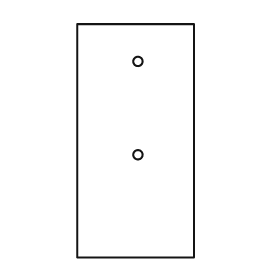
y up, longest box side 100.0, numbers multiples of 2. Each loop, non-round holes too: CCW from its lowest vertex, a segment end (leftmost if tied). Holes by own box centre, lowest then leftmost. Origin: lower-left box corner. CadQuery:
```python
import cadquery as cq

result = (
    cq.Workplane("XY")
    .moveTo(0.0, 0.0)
    .lineTo(50.0, 0.0)
    .lineTo(50.0, 100.0)
    .lineTo(0.0, 100.0)
    .close()
    .moveTo(26.0, 44.0)
    .circle(2.0)
    .moveTo(26.0, 84.0)
    .circle(2.0)
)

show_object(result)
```